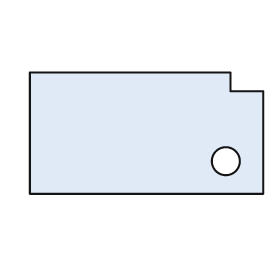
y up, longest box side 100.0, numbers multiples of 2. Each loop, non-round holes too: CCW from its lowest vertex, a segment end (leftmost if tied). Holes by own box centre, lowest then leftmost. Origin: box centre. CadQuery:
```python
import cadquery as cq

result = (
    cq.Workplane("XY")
    .moveTo(-50.0, -26.0)
    .lineTo(50.0, -26.0)
    .lineTo(50.0, 18.0)
    .lineTo(36.0, 18.0)
    .lineTo(36.0, 26.0)
    .lineTo(-50.0, 26.0)
    .close()
    .moveTo(34.0, -12.0)
    .circle(6.0)
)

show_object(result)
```